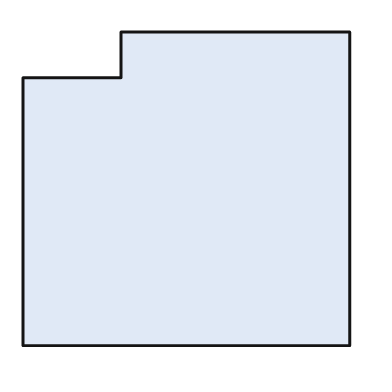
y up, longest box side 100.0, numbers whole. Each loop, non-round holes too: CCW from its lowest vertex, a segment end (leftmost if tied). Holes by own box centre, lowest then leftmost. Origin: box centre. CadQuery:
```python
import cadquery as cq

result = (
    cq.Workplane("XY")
    .moveTo(-50.0, -48.0)
    .lineTo(50.0, -48.0)
    .lineTo(50.0, 48.0)
    .lineTo(-20.0, 48.0)
    .lineTo(-20.0, 34.0)
    .lineTo(-50.0, 34.0)
    .close()
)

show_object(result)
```